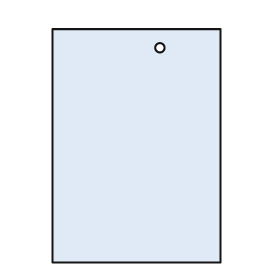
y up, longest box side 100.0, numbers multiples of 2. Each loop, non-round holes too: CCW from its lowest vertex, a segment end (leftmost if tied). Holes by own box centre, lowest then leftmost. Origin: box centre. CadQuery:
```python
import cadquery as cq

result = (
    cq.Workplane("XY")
    .moveTo(-36.0, -50.0)
    .lineTo(36.0, -50.0)
    .lineTo(36.0, 50.0)
    .lineTo(-36.0, 50.0)
    .close()
    .moveTo(10.0, 42.0)
    .circle(2.0)
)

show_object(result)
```